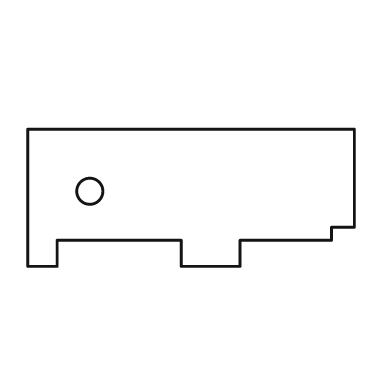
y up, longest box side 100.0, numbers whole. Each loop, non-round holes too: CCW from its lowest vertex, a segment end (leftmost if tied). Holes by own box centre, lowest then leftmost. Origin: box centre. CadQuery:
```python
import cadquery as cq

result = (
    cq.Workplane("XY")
    .moveTo(-50.0, -21.0)
    .lineTo(-41.0, -21.0)
    .lineTo(-41.0, -13.0)
    .lineTo(-3.0, -13.0)
    .lineTo(-3.0, -21.0)
    .lineTo(15.0, -21.0)
    .lineTo(15.0, -13.0)
    .lineTo(43.0, -13.0)
    .lineTo(43.0, -9.0)
    .lineTo(50.0, -9.0)
    .lineTo(50.0, 21.0)
    .lineTo(-50.0, 21.0)
    .close()
    .moveTo(-31.0, 2.0)
    .circle(4.0)
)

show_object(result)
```